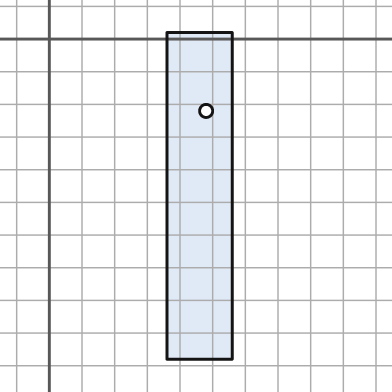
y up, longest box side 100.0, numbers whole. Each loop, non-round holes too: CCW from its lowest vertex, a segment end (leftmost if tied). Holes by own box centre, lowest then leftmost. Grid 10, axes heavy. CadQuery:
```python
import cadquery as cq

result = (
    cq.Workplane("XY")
    .moveTo(36.0, -98.0)
    .lineTo(56.0, -98.0)
    .lineTo(56.0, 2.0)
    .lineTo(36.0, 2.0)
    .close()
    .moveTo(48.0, -22.0)
    .circle(2.0)
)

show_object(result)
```